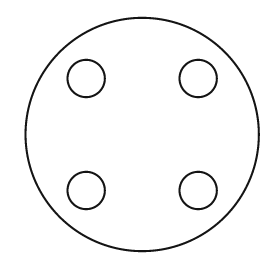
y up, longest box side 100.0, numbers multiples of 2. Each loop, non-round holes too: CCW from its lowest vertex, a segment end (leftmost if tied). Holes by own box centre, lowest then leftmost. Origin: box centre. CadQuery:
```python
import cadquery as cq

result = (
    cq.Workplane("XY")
    .moveTo(0.0, 0.0)
    .circle(50.0)
    .moveTo(-24.0, -24.0)
    .circle(8.0)
    .moveTo(24.0, -24.0)
    .circle(8.0)
    .moveTo(-24.0, 24.0)
    .circle(8.0)
    .moveTo(24.0, 24.0)
    .circle(8.0)
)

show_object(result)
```